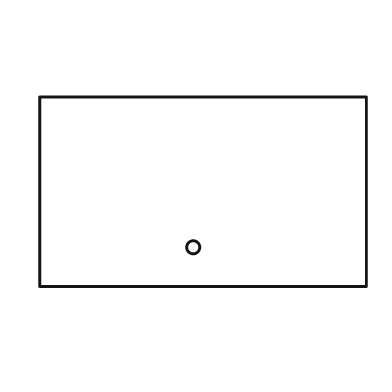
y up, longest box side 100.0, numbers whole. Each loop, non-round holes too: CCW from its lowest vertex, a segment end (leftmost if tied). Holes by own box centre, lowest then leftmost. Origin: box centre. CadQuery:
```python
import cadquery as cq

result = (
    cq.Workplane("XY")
    .moveTo(-50.0, -29.0)
    .lineTo(50.0, -29.0)
    .lineTo(50.0, 29.0)
    .lineTo(-50.0, 29.0)
    .close()
    .moveTo(-3.0, -17.0)
    .circle(2.0)
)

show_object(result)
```